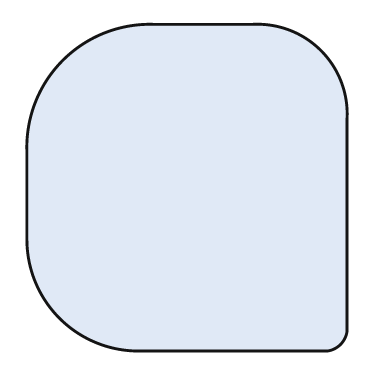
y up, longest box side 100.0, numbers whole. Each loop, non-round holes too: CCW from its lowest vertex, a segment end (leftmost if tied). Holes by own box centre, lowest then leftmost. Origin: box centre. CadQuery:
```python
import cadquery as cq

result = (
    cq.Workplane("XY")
    .moveTo(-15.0, -50.0)
    .lineTo(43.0, -50.0)
    .threePointArc((47.0, -48.0), (49.0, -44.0))
    .lineTo(49.0, 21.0)
    .threePointArc((41.0, 42.0), (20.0, 50.0))
    .lineTo(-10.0, 50.0)
    .threePointArc((-38.0, 39.0), (-49.0, 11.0))
    .lineTo(-49.0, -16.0)
    .threePointArc((-39.0, -40.0), (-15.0, -50.0))
    .close()
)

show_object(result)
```